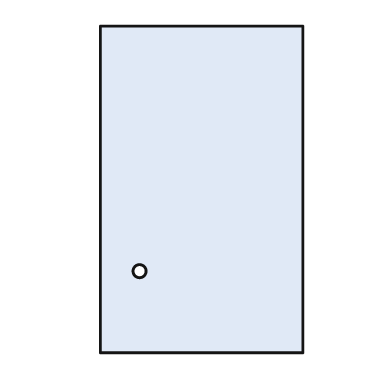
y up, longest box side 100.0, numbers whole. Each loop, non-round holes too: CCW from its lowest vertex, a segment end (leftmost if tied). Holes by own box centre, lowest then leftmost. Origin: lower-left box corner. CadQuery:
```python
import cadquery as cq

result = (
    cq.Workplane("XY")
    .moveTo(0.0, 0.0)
    .lineTo(62.0, 0.0)
    .lineTo(62.0, 100.0)
    .lineTo(0.0, 100.0)
    .close()
    .moveTo(12.0, 25.0)
    .circle(2.0)
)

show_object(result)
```